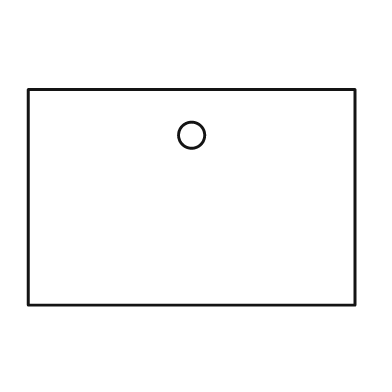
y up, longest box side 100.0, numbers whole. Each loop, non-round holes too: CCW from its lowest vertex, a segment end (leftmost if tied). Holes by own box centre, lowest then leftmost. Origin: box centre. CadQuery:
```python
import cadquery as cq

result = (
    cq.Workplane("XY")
    .moveTo(-50.0, -33.0)
    .lineTo(50.0, -33.0)
    .lineTo(50.0, 33.0)
    .lineTo(-50.0, 33.0)
    .close()
    .moveTo(0.0, 19.0)
    .circle(4.0)
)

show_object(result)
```